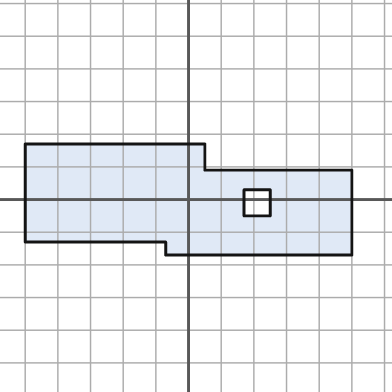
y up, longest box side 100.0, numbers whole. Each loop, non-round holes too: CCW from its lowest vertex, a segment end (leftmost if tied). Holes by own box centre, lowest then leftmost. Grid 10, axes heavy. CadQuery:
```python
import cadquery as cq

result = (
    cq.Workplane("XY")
    .moveTo(-7.0, -17.0)
    .lineTo(50.0, -17.0)
    .lineTo(50.0, 9.0)
    .lineTo(5.0, 9.0)
    .lineTo(5.0, 17.0)
    .lineTo(-50.0, 17.0)
    .lineTo(-50.0, -13.0)
    .lineTo(-7.0, -13.0)
    .close()
    .moveTo(17.0, -5.0)
    .lineTo(25.0, -5.0)
    .lineTo(25.0, 3.0)
    .lineTo(17.0, 3.0)
    .close()
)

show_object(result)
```